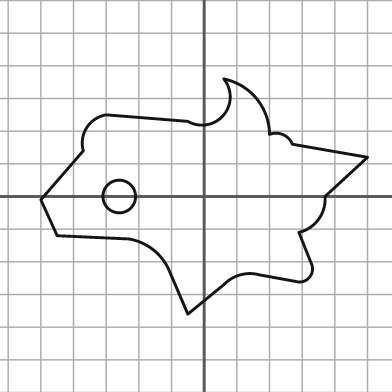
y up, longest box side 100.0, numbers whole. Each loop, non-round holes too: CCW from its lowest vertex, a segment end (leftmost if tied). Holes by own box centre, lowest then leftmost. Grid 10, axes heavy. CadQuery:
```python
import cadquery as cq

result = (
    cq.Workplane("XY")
    .moveTo(-5.0, -36.0)
    .lineTo(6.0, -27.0)
    .threePointArc((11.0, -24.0), (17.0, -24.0))
    .lineTo(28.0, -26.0)
    .threePointArc((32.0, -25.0), (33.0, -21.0))
    .lineTo(29.0, -11.0)
    .threePointArc((35.0, -7.0), (37.0, 0.0))
    .lineTo(50.0, 12.0)
    .lineTo(27.0, 16.0)
    .threePointArc((24.0, 19.0), (20.0, 19.0))
    .threePointArc((16.0, 30.0), (6.0, 36.0))
    .threePointArc((6.0, 25.0), (-5.0, 23.0))
    .lineTo(-30.0, 25.0)
    .threePointArc((-36.0, 21.0), (-37.0, 14.0))
    .lineTo(-50.0, -1.0)
    .lineTo(-45.0, -12.0)
    .lineTo(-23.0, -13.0)
    .threePointArc((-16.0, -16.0), (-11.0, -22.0))
    .close()
    .moveTo(-26.0, 0.0)
    .circle(5.0)
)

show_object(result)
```